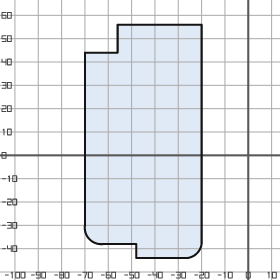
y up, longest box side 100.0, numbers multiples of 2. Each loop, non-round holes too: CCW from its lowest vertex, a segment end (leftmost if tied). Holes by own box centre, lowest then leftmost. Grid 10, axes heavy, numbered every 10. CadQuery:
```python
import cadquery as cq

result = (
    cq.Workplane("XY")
    .moveTo(-48.0, -44.0)
    .lineTo(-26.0, -44.0)
    .threePointArc((-22.0, -42.0), (-20.0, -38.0))
    .lineTo(-20.0, 56.0)
    .lineTo(-56.0, 56.0)
    .lineTo(-56.0, 44.0)
    .lineTo(-70.0, 44.0)
    .lineTo(-70.0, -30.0)
    .threePointArc((-68.0, -36.0), (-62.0, -38.0))
    .lineTo(-48.0, -38.0)
    .close()
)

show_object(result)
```